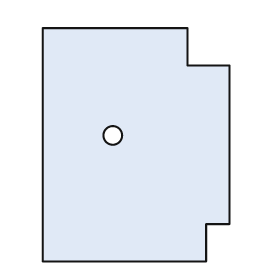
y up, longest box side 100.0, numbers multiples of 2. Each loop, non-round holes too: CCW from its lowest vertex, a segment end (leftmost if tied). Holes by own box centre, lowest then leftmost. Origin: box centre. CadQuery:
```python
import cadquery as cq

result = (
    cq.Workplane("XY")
    .moveTo(-40.0, -50.0)
    .lineTo(30.0, -50.0)
    .lineTo(30.0, -34.0)
    .lineTo(40.0, -34.0)
    .lineTo(40.0, 34.0)
    .lineTo(22.0, 34.0)
    .lineTo(22.0, 50.0)
    .lineTo(-40.0, 50.0)
    .close()
    .moveTo(-10.0, 4.0)
    .circle(4.0)
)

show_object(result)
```